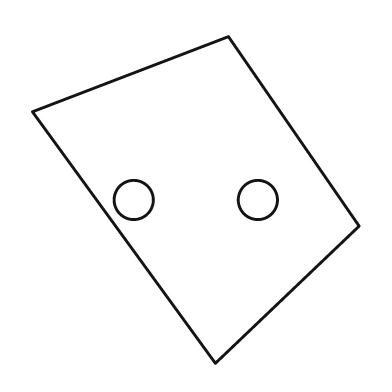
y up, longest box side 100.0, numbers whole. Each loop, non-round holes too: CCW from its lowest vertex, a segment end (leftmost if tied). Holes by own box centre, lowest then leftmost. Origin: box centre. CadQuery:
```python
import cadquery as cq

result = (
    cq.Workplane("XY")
    .moveTo(6.0, -50.0)
    .lineTo(50.0, -8.0)
    .lineTo(10.0, 50.0)
    .lineTo(-50.0, 27.0)
    .close()
    .moveTo(-19.0, 0.0)
    .circle(6.0)
    .moveTo(19.0, 0.0)
    .circle(6.0)
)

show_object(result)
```